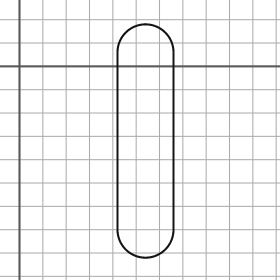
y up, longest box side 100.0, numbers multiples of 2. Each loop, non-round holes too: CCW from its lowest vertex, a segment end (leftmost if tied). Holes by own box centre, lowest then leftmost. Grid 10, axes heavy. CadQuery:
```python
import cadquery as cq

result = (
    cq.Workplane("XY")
    .moveTo(42.0, -70.0)
    .threePointArc((54.0, -82.0), (66.0, -70.0))
    .lineTo(66.0, 6.0)
    .threePointArc((54.0, 18.0), (42.0, 6.0))
    .close()
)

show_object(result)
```